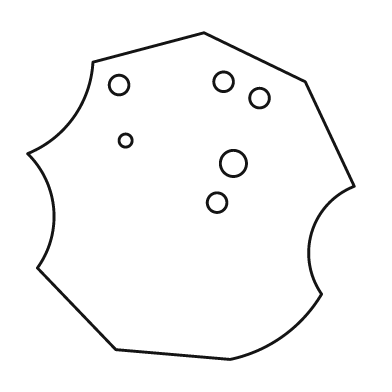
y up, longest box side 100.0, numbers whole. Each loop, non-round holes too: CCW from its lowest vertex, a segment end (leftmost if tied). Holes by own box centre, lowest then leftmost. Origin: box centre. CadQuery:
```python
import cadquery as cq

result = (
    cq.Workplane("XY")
    .moveTo(12.0, -50.0)
    .threePointArc((28.0, -43.0), (40.0, -30.0))
    .threePointArc((37.0, -11.0), (50.0, 3.0))
    .lineTo(35.0, 35.0)
    .lineTo(4.0, 50.0)
    .lineTo(-30.0, 41.0)
    .threePointArc((-36.0, 24.0), (-50.0, 13.0))
    .threePointArc((-42.0, -4.0), (-47.0, -22.0))
    .lineTo(-23.0, -47.0)
    .close()
    .moveTo(8.0, -2.0)
    .circle(3.0)
    .moveTo(13.0, 10.0)
    .circle(4.0)
    .moveTo(-20.0, 17.0)
    .circle(2.0)
    .moveTo(21.0, 30.0)
    .circle(3.0)
    .moveTo(-22.0, 34.0)
    .circle(3.0)
    .moveTo(10.0, 35.0)
    .circle(3.0)
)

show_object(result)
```